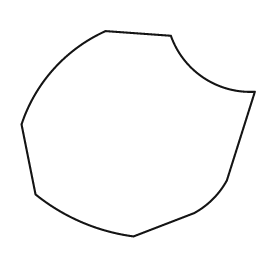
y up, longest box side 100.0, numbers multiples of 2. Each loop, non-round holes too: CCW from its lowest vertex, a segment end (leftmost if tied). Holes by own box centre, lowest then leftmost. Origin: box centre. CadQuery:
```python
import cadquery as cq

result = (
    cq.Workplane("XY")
    .moveTo(-2.0, -44.0)
    .lineTo(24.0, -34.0)
    .threePointArc((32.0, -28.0), (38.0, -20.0))
    .lineTo(50.0, 18.0)
    .threePointArc((28.0, 24.0), (14.0, 42.0))
    .lineTo(-14.0, 44.0)
    .threePointArc((-36.0, 28.0), (-50.0, 4.0))
    .lineTo(-44.0, -26.0)
    .threePointArc((-24.0, -38.0), (-2.0, -44.0))
    .close()
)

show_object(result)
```